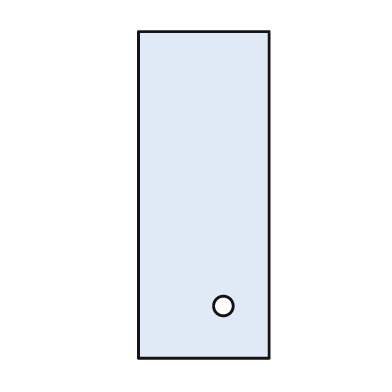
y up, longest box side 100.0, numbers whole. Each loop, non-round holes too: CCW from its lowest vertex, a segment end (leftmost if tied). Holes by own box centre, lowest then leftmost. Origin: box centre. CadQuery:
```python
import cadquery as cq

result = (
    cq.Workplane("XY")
    .moveTo(-20.0, -50.0)
    .lineTo(20.0, -50.0)
    .lineTo(20.0, 50.0)
    .lineTo(-20.0, 50.0)
    .close()
    .moveTo(6.0, -34.0)
    .circle(3.0)
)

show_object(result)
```